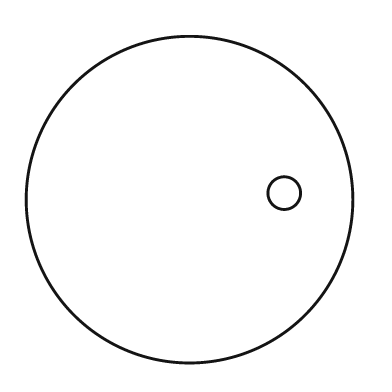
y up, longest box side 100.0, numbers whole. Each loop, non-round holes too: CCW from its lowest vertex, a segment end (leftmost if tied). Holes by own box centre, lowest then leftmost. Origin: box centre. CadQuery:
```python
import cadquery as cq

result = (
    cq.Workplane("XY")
    .moveTo(0.0, 0.0)
    .circle(50.0)
    .moveTo(29.0, 2.0)
    .circle(5.0)
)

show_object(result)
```